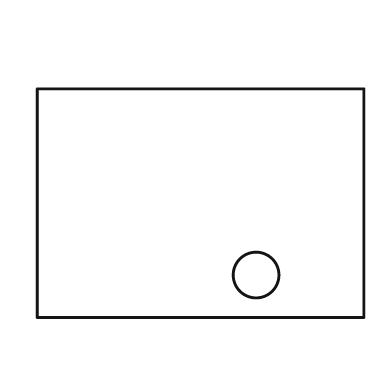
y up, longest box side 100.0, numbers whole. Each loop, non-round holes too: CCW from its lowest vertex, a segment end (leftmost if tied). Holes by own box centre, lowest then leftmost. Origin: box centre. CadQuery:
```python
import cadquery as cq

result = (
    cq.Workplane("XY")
    .moveTo(-50.0, -35.0)
    .lineTo(50.0, -35.0)
    .lineTo(50.0, 35.0)
    .lineTo(-50.0, 35.0)
    .close()
    .moveTo(17.0, -22.0)
    .circle(7.0)
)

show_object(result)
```